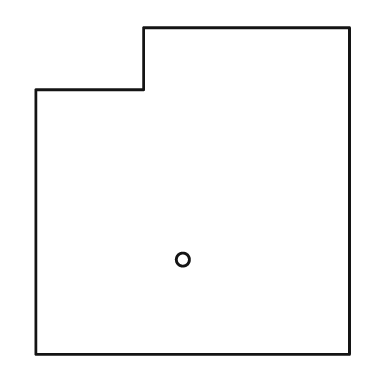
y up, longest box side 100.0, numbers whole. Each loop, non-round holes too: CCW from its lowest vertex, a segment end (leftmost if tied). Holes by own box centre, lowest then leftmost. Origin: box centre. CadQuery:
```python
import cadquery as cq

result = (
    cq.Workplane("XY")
    .moveTo(-48.0, -50.0)
    .lineTo(48.0, -50.0)
    .lineTo(48.0, 50.0)
    .lineTo(-15.0, 50.0)
    .lineTo(-15.0, 31.0)
    .lineTo(-48.0, 31.0)
    .close()
    .moveTo(-3.0, -21.0)
    .circle(2.0)
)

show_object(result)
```